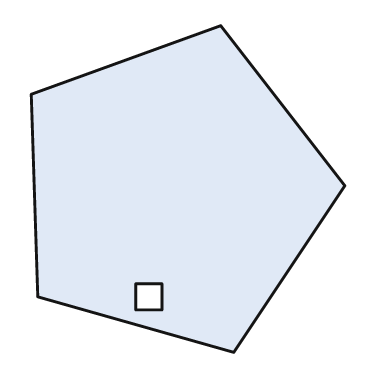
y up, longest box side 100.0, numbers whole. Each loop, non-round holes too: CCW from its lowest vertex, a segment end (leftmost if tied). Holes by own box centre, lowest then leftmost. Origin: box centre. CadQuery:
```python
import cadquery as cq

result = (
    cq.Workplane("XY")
    .moveTo(14.0, -50.0)
    .lineTo(48.0, 1.0)
    .lineTo(10.0, 50.0)
    .lineTo(-48.0, 29.0)
    .lineTo(-46.0, -33.0)
    .close()
    .moveTo(-16.0, -37.0)
    .lineTo(-8.0, -37.0)
    .lineTo(-8.0, -29.0)
    .lineTo(-16.0, -29.0)
    .close()
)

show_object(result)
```